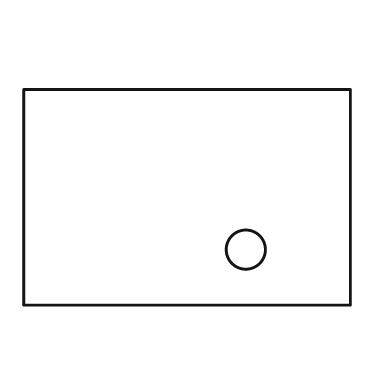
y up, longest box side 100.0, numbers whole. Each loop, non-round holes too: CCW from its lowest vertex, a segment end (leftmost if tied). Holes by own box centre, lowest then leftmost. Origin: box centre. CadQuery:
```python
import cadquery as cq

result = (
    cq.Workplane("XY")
    .moveTo(-50.0, -33.0)
    .lineTo(50.0, -33.0)
    .lineTo(50.0, 33.0)
    .lineTo(-50.0, 33.0)
    .close()
    .moveTo(18.0, -16.0)
    .circle(6.0)
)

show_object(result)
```